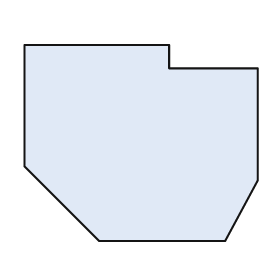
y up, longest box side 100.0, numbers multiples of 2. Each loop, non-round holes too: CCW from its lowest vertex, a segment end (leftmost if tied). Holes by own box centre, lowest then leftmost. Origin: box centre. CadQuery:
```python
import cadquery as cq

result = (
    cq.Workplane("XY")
    .moveTo(-18.0, -42.0)
    .lineTo(36.0, -42.0)
    .lineTo(50.0, -16.0)
    .lineTo(50.0, 32.0)
    .lineTo(12.0, 32.0)
    .lineTo(12.0, 42.0)
    .lineTo(-50.0, 42.0)
    .lineTo(-50.0, -10.0)
    .close()
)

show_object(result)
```